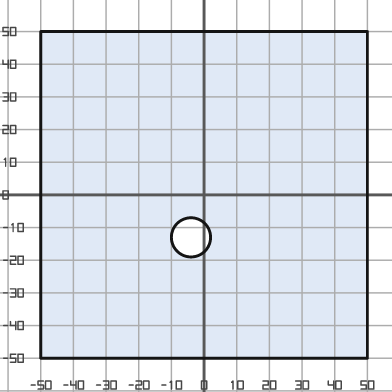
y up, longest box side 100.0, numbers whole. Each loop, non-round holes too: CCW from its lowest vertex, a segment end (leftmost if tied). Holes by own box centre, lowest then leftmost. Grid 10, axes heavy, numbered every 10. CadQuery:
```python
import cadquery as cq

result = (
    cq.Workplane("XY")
    .moveTo(-50.0, -50.0)
    .lineTo(50.0, -50.0)
    .lineTo(50.0, 50.0)
    .lineTo(-50.0, 50.0)
    .close()
    .moveTo(-4.0, -13.0)
    .circle(6.0)
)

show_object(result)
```